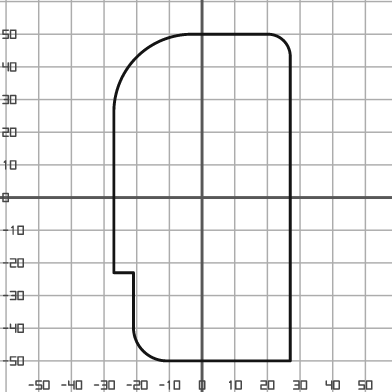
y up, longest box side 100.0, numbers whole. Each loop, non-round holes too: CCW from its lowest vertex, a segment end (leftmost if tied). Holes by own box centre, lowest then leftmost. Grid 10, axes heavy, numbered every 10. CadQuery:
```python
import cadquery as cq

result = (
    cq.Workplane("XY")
    .moveTo(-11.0, -50.0)
    .lineTo(27.0, -50.0)
    .lineTo(27.0, 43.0)
    .threePointArc((25.0, 48.0), (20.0, 50.0))
    .lineTo(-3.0, 50.0)
    .threePointArc((-20.0, 43.0), (-27.0, 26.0))
    .lineTo(-27.0, -23.0)
    .lineTo(-21.0, -23.0)
    .lineTo(-21.0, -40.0)
    .threePointArc((-18.0, -47.0), (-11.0, -50.0))
    .close()
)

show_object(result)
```